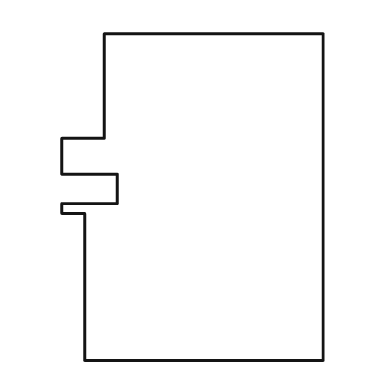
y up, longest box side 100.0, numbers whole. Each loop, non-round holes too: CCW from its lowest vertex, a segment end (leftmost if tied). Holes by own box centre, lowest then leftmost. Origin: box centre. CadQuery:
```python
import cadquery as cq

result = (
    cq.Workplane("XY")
    .moveTo(-33.0, -50.0)
    .lineTo(40.0, -50.0)
    .lineTo(40.0, 50.0)
    .lineTo(-27.0, 50.0)
    .lineTo(-27.0, 18.0)
    .lineTo(-40.0, 18.0)
    .lineTo(-40.0, 7.0)
    .lineTo(-23.0, 7.0)
    .lineTo(-23.0, -2.0)
    .lineTo(-40.0, -2.0)
    .lineTo(-40.0, -5.0)
    .lineTo(-33.0, -5.0)
    .close()
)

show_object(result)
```